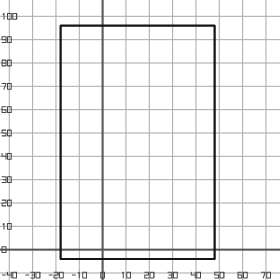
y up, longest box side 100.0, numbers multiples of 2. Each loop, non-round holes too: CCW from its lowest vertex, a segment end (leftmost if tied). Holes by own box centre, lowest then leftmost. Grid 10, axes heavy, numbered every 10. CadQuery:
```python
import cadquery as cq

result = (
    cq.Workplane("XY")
    .moveTo(-18.0, -4.0)
    .lineTo(48.0, -4.0)
    .lineTo(48.0, 96.0)
    .lineTo(-18.0, 96.0)
    .close()
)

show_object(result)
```